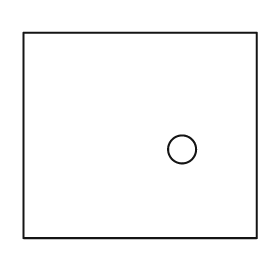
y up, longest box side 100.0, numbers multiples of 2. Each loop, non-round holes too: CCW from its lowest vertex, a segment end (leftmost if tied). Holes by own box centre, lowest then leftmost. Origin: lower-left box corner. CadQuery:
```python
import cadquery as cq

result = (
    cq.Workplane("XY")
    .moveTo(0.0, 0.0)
    .lineTo(100.0, 0.0)
    .lineTo(100.0, 88.0)
    .lineTo(0.0, 88.0)
    .close()
    .moveTo(68.0, 38.0)
    .circle(6.0)
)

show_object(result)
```